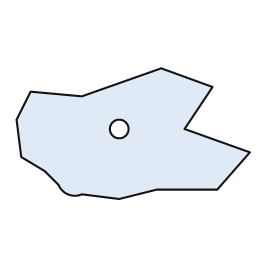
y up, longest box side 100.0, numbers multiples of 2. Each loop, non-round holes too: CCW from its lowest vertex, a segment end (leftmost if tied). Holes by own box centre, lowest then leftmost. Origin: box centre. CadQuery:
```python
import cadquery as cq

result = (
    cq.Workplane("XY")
    .moveTo(-6.0, -28.0)
    .lineTo(10.0, -24.0)
    .lineTo(36.0, -24.0)
    .lineTo(50.0, -8.0)
    .lineTo(22.0, 2.0)
    .lineTo(34.0, 20.0)
    .lineTo(12.0, 28.0)
    .lineTo(-22.0, 16.0)
    .lineTo(-44.0, 18.0)
    .lineTo(-50.0, 6.0)
    .lineTo(-48.0, -10.0)
    .lineTo(-38.0, -16.0)
    .lineTo(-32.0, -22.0)
    .threePointArc((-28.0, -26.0), (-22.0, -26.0))
    .close()
    .moveTo(-6.0, 2.0)
    .circle(4.0)
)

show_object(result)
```